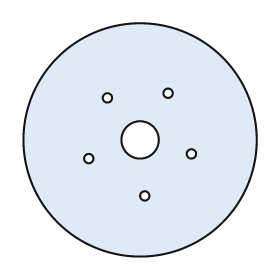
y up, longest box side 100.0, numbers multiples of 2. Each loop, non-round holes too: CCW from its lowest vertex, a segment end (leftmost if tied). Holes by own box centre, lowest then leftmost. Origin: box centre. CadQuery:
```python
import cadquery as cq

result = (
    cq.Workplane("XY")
    .moveTo(0.0, 0.0)
    .circle(50.0)
    .moveTo(2.0, -24.0)
    .circle(2.0)
    .moveTo(-22.0, -8.0)
    .circle(2.0)
    .moveTo(22.0, -6.0)
    .circle(2.0)
    .moveTo(0.0, 0.0)
    .circle(8.0)
    .moveTo(-14.0, 18.0)
    .circle(2.0)
    .moveTo(12.0, 20.0)
    .circle(2.0)
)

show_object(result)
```